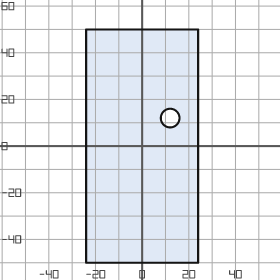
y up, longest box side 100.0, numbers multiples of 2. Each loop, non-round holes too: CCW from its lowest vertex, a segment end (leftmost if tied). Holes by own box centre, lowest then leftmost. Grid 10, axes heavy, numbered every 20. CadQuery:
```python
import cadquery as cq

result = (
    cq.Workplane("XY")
    .moveTo(-24.0, -50.0)
    .lineTo(24.0, -50.0)
    .lineTo(24.0, 50.0)
    .lineTo(-24.0, 50.0)
    .close()
    .moveTo(12.0, 12.0)
    .circle(4.0)
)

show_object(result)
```